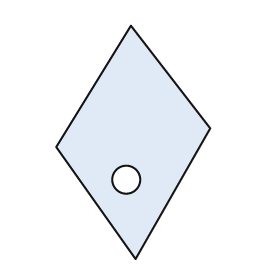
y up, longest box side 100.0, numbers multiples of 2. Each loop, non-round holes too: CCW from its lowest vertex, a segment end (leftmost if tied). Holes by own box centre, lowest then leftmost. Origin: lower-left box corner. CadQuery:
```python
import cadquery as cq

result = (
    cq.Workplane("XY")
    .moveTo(34.0, 0.0)
    .lineTo(66.0, 56.0)
    .lineTo(32.0, 100.0)
    .lineTo(0.0, 48.0)
    .close()
    .moveTo(30.0, 34.0)
    .circle(6.0)
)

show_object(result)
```